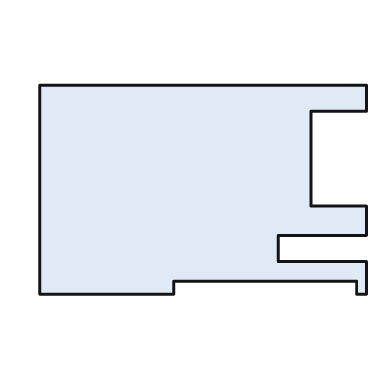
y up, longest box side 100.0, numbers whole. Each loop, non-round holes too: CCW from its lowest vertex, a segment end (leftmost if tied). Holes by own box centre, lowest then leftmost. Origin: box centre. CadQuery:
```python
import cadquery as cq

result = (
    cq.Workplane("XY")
    .moveTo(-50.0, -32.0)
    .lineTo(-9.0, -32.0)
    .lineTo(-9.0, -28.0)
    .lineTo(47.0, -28.0)
    .lineTo(47.0, -32.0)
    .lineTo(50.0, -32.0)
    .lineTo(50.0, -22.0)
    .lineTo(23.0, -22.0)
    .lineTo(23.0, -14.0)
    .lineTo(50.0, -14.0)
    .lineTo(50.0, -5.0)
    .lineTo(33.0, -5.0)
    .lineTo(33.0, 24.0)
    .lineTo(50.0, 24.0)
    .lineTo(50.0, 32.0)
    .lineTo(-50.0, 32.0)
    .close()
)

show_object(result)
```